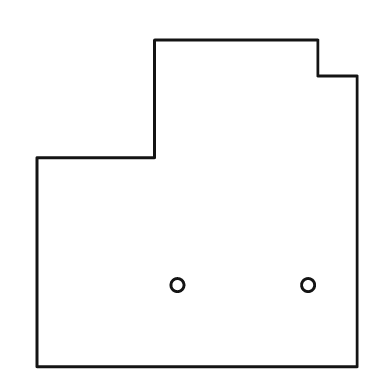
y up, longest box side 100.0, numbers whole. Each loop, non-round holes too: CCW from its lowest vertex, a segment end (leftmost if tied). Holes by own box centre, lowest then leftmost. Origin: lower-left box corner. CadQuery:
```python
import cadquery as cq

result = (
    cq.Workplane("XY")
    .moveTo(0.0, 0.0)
    .lineTo(98.0, 0.0)
    .lineTo(98.0, 89.0)
    .lineTo(86.0, 89.0)
    .lineTo(86.0, 100.0)
    .lineTo(36.0, 100.0)
    .lineTo(36.0, 64.0)
    .lineTo(0.0, 64.0)
    .close()
    .moveTo(43.0, 25.0)
    .circle(2.0)
    .moveTo(83.0, 25.0)
    .circle(2.0)
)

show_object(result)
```